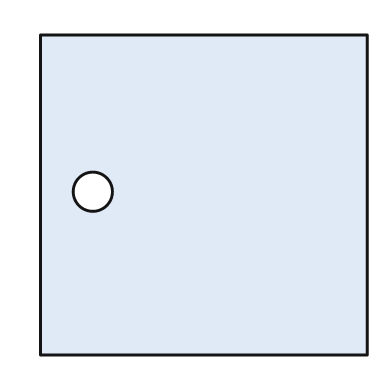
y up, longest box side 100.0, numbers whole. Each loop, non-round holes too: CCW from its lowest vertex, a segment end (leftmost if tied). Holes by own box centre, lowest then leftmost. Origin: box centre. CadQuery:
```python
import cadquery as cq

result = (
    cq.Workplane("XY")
    .moveTo(-50.0, -49.0)
    .lineTo(50.0, -49.0)
    .lineTo(50.0, 49.0)
    .lineTo(-50.0, 49.0)
    .close()
    .moveTo(-34.0, 1.0)
    .circle(6.0)
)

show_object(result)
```